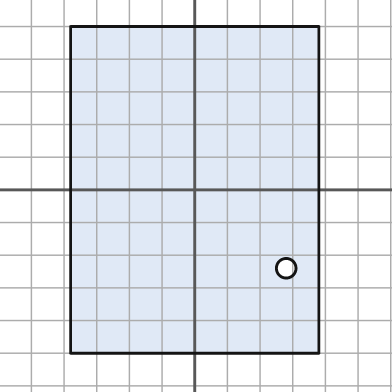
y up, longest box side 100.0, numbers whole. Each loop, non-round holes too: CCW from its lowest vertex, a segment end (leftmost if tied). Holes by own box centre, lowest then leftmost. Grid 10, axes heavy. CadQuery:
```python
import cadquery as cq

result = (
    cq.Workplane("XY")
    .moveTo(-38.0, -50.0)
    .lineTo(38.0, -50.0)
    .lineTo(38.0, 50.0)
    .lineTo(-38.0, 50.0)
    .close()
    .moveTo(28.0, -24.0)
    .circle(3.0)
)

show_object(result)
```